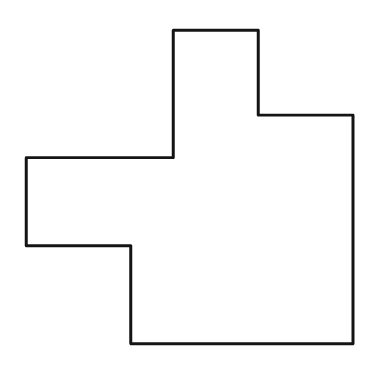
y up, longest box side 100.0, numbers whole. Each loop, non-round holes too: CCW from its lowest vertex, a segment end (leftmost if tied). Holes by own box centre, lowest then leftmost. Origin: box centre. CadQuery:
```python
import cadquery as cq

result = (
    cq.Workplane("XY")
    .moveTo(-18.0, -48.0)
    .lineTo(50.0, -48.0)
    .lineTo(50.0, 22.0)
    .lineTo(21.0, 22.0)
    .lineTo(21.0, 48.0)
    .lineTo(-5.0, 48.0)
    .lineTo(-5.0, 9.0)
    .lineTo(-50.0, 9.0)
    .lineTo(-50.0, -18.0)
    .lineTo(-18.0, -18.0)
    .close()
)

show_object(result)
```